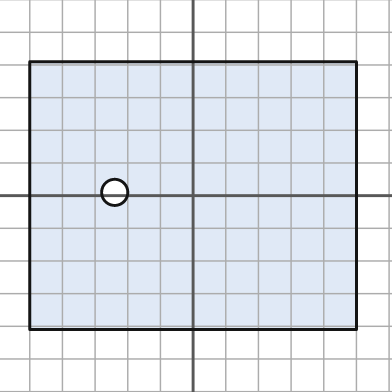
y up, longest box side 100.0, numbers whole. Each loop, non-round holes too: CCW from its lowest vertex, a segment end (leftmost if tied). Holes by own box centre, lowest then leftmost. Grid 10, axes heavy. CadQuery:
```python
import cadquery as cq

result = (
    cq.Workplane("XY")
    .moveTo(-50.0, -41.0)
    .lineTo(50.0, -41.0)
    .lineTo(50.0, 41.0)
    .lineTo(-50.0, 41.0)
    .close()
    .moveTo(-24.0, 1.0)
    .circle(4.0)
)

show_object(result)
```